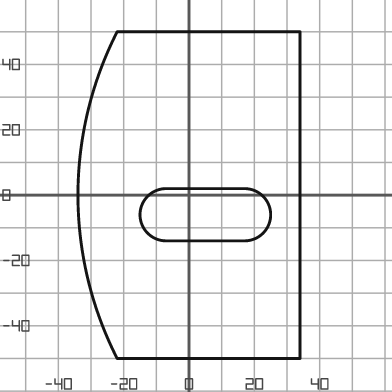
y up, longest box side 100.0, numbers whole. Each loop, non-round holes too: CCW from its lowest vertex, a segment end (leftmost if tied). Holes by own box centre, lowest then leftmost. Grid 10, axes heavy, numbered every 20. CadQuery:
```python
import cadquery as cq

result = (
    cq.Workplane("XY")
    .moveTo(-22.0, -50.0)
    .lineTo(34.0, -50.0)
    .lineTo(34.0, 50.0)
    .lineTo(-22.0, 50.0)
    .threePointArc((-34.0, 0.0), (-22.0, -50.0))
    .close()
    .moveTo(-7.0, -14.0)
    .lineTo(17.0, -14.0)
    .threePointArc((25.0, -6.0), (17.0, 2.0))
    .lineTo(-7.0, 2.0)
    .threePointArc((-15.0, -6.0), (-7.0, -14.0))
    .close()
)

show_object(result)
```